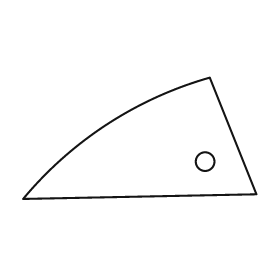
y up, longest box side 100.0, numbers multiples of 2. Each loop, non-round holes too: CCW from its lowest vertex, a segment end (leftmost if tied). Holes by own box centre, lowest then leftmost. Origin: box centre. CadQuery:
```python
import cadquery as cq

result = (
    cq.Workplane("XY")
    .moveTo(-50.0, -26.0)
    .lineTo(50.0, -24.0)
    .lineTo(30.0, 26.0)
    .threePointArc((-14.0, 6.0), (-50.0, -26.0))
    .close()
    .moveTo(28.0, -10.0)
    .circle(4.0)
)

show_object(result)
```